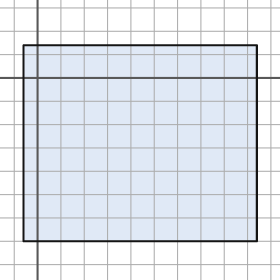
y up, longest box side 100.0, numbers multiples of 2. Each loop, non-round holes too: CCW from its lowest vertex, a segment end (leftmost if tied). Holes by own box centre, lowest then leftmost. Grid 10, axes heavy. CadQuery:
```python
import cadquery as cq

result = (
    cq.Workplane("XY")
    .moveTo(-6.0, -70.0)
    .lineTo(94.0, -70.0)
    .lineTo(94.0, 14.0)
    .lineTo(-6.0, 14.0)
    .close()
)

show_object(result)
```